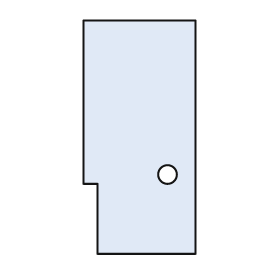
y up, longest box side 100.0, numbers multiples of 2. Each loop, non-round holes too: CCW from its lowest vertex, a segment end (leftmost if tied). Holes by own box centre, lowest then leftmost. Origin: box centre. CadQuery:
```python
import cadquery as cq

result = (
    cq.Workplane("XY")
    .moveTo(-18.0, -50.0)
    .lineTo(24.0, -50.0)
    .lineTo(24.0, 50.0)
    .lineTo(-24.0, 50.0)
    .lineTo(-24.0, -20.0)
    .lineTo(-18.0, -20.0)
    .close()
    .moveTo(12.0, -16.0)
    .circle(4.0)
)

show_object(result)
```